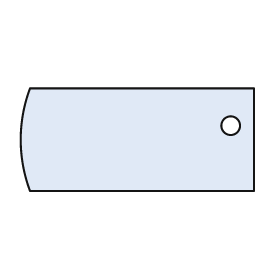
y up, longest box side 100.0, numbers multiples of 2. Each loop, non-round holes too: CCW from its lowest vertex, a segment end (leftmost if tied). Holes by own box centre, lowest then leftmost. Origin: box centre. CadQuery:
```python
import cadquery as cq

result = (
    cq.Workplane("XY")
    .moveTo(-46.0, -22.0)
    .lineTo(50.0, -22.0)
    .lineTo(50.0, 22.0)
    .lineTo(-46.0, 22.0)
    .threePointArc((-50.0, 0.0), (-46.0, -22.0))
    .close()
    .moveTo(40.0, 6.0)
    .circle(4.0)
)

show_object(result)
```